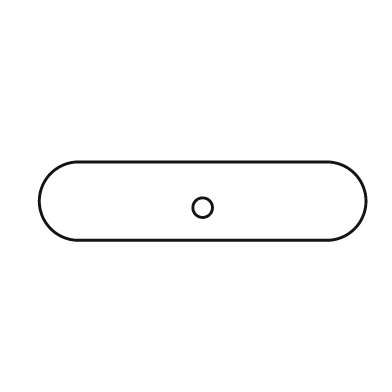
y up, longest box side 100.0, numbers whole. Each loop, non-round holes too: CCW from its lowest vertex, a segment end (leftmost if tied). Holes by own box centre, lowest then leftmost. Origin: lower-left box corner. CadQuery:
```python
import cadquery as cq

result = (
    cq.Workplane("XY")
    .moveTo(12.0, 0.0)
    .lineTo(88.0, 0.0)
    .threePointArc((100.0, 12.0), (88.0, 24.0))
    .lineTo(12.0, 24.0)
    .threePointArc((0.0, 12.0), (12.0, 0.0))
    .close()
    .moveTo(50.0, 10.0)
    .circle(3.0)
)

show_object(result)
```